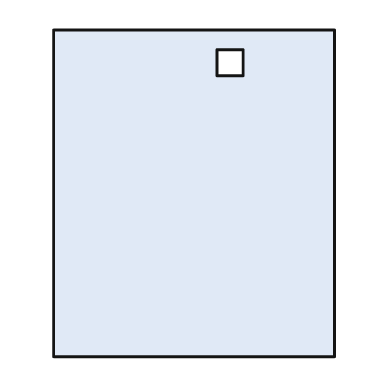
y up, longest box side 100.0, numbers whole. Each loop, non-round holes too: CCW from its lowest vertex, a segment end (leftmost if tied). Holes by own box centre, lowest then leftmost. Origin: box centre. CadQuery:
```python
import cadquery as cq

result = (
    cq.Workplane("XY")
    .moveTo(-43.0, -50.0)
    .lineTo(43.0, -50.0)
    .lineTo(43.0, 50.0)
    .lineTo(-43.0, 50.0)
    .close()
    .moveTo(7.0, 36.0)
    .lineTo(15.0, 36.0)
    .lineTo(15.0, 44.0)
    .lineTo(7.0, 44.0)
    .close()
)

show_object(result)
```